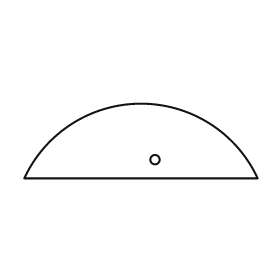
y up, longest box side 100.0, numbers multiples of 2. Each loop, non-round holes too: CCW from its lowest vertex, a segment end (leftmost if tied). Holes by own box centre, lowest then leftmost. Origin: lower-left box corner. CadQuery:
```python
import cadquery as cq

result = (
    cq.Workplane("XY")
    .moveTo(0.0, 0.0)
    .lineTo(100.0, 0.0)
    .threePointArc((50.0, 32.0), (0.0, 0.0))
    .close()
    .moveTo(56.0, 8.0)
    .circle(2.0)
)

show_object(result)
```